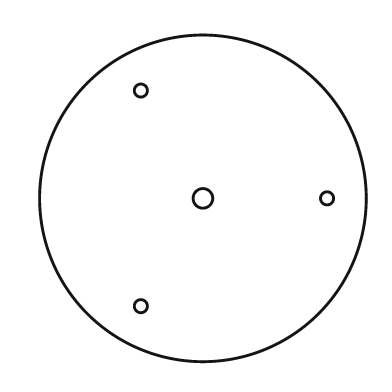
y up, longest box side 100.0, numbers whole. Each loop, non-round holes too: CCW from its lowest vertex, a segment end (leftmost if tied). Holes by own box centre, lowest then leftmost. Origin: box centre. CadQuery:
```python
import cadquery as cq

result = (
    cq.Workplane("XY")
    .moveTo(0.0, 0.0)
    .circle(50.0)
    .moveTo(-19.0, -33.0)
    .circle(2.0)
    .moveTo(0.0, 0.0)
    .circle(3.0)
    .moveTo(38.0, 0.0)
    .circle(2.0)
    .moveTo(-19.0, 33.0)
    .circle(2.0)
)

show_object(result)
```